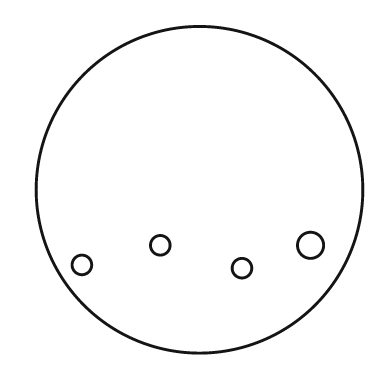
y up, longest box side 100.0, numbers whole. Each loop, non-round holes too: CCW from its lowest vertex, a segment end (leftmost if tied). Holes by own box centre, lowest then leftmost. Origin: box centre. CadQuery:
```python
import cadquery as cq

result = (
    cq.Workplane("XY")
    .moveTo(0.0, 0.0)
    .circle(50.0)
    .moveTo(13.0, -24.0)
    .circle(3.0)
    .moveTo(-36.0, -23.0)
    .circle(3.0)
    .moveTo(-12.0, -17.0)
    .circle(3.0)
    .moveTo(34.0, -17.0)
    .circle(4.0)
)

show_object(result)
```